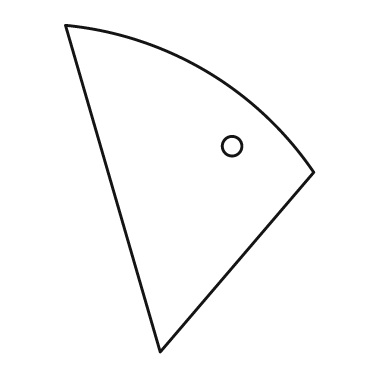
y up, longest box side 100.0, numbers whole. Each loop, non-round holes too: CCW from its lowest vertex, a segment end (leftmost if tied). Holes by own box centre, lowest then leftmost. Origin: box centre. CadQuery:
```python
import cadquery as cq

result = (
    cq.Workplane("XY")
    .moveTo(-9.0, -50.0)
    .lineTo(38.0, 5.0)
    .threePointArc((5.0, 36.0), (-38.0, 50.0))
    .close()
    .moveTo(13.0, 13.0)
    .circle(3.0)
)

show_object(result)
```